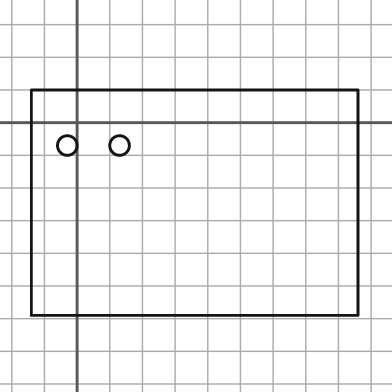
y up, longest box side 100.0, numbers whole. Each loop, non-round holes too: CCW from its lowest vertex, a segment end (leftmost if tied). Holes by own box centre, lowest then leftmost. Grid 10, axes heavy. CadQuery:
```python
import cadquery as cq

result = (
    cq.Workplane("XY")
    .moveTo(-14.0, -59.0)
    .lineTo(86.0, -59.0)
    .lineTo(86.0, 10.0)
    .lineTo(-14.0, 10.0)
    .close()
    .moveTo(-3.0, -7.0)
    .circle(3.0)
    .moveTo(13.0, -7.0)
    .circle(3.0)
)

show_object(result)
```